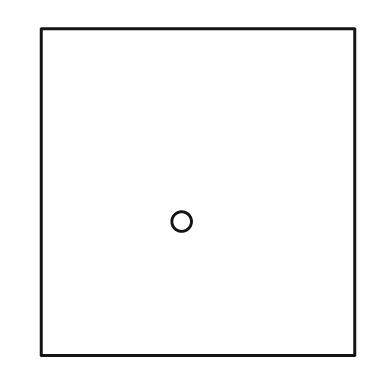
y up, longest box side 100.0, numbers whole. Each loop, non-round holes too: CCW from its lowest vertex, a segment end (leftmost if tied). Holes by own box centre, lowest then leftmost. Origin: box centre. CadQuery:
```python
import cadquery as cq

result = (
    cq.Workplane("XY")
    .moveTo(-48.0, -50.0)
    .lineTo(48.0, -50.0)
    .lineTo(48.0, 50.0)
    .lineTo(-48.0, 50.0)
    .close()
    .moveTo(-5.0, -9.0)
    .circle(3.0)
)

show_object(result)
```